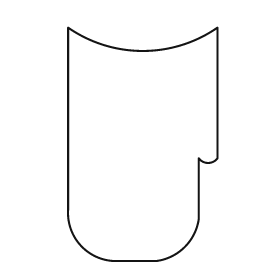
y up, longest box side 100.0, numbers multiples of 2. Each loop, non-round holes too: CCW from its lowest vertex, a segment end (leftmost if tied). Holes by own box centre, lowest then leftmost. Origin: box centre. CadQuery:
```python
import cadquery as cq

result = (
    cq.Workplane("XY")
    .moveTo(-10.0, -50.0)
    .lineTo(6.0, -50.0)
    .threePointArc((18.0, -44.0), (24.0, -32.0))
    .lineTo(24.0, -6.0)
    .threePointArc((28.0, -8.0), (32.0, -6.0))
    .lineTo(32.0, 50.0)
    .threePointArc((0.0, 40.0), (-32.0, 50.0))
    .lineTo(-32.0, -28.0)
    .threePointArc((-26.0, -44.0), (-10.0, -50.0))
    .close()
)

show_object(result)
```